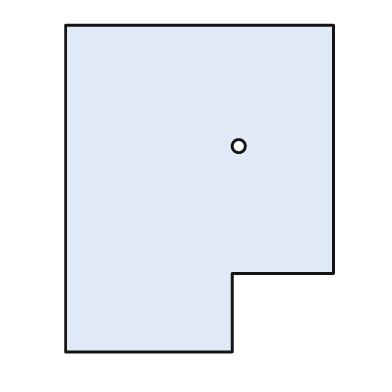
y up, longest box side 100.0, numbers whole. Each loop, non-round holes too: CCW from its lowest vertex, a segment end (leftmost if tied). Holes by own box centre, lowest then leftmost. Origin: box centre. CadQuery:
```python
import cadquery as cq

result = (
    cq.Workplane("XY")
    .moveTo(-41.0, -50.0)
    .lineTo(10.0, -50.0)
    .lineTo(10.0, -26.0)
    .lineTo(41.0, -26.0)
    .lineTo(41.0, 50.0)
    .lineTo(-41.0, 50.0)
    .close()
    .moveTo(12.0, 13.0)
    .circle(2.0)
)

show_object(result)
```